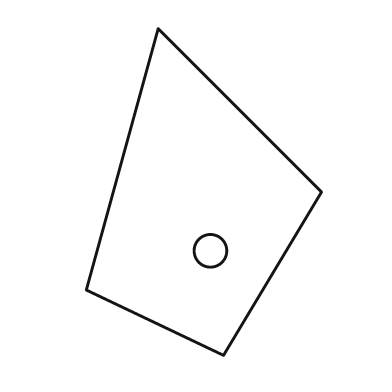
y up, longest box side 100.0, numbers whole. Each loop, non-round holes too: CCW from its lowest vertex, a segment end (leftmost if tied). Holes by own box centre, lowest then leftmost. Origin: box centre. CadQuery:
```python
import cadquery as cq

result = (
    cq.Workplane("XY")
    .moveTo(6.0, -50.0)
    .lineTo(36.0, 0.0)
    .lineTo(-14.0, 50.0)
    .lineTo(-36.0, -30.0)
    .close()
    .moveTo(2.0, -18.0)
    .circle(5.0)
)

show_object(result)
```